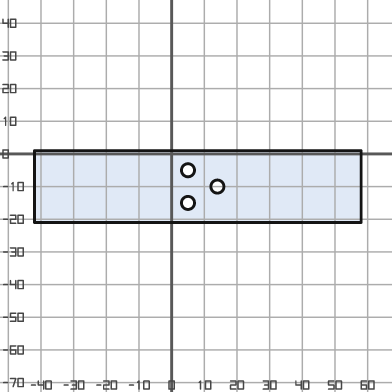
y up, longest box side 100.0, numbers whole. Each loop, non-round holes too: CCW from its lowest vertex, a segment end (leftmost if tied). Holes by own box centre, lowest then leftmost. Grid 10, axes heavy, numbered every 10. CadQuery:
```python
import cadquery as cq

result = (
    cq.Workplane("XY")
    .moveTo(-42.0, -21.0)
    .lineTo(58.0, -21.0)
    .lineTo(58.0, 1.0)
    .lineTo(-42.0, 1.0)
    .close()
    .moveTo(5.0, -15.0)
    .circle(2.0)
    .moveTo(14.0, -10.0)
    .circle(2.0)
    .moveTo(5.0, -5.0)
    .circle(2.0)
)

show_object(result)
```